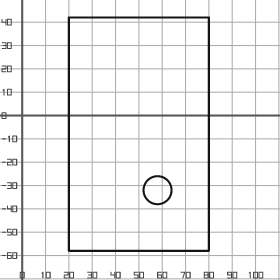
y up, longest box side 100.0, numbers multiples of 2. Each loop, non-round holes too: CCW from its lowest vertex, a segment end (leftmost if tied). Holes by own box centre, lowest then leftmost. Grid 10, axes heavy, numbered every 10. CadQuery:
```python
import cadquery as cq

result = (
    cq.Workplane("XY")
    .moveTo(20.0, -58.0)
    .lineTo(80.0, -58.0)
    .lineTo(80.0, 42.0)
    .lineTo(20.0, 42.0)
    .close()
    .moveTo(58.0, -32.0)
    .circle(6.0)
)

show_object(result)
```